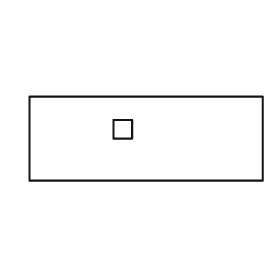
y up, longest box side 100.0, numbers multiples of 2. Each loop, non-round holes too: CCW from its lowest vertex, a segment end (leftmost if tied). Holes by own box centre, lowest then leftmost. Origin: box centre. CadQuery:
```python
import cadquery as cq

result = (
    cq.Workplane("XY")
    .moveTo(-50.0, -18.0)
    .lineTo(50.0, -18.0)
    .lineTo(50.0, 18.0)
    .lineTo(-50.0, 18.0)
    .close()
    .moveTo(-14.0, 0.0)
    .lineTo(-6.0, 0.0)
    .lineTo(-6.0, 8.0)
    .lineTo(-14.0, 8.0)
    .close()
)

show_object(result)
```